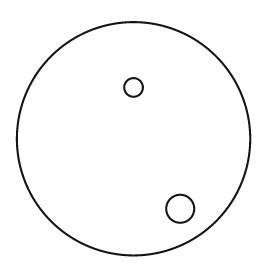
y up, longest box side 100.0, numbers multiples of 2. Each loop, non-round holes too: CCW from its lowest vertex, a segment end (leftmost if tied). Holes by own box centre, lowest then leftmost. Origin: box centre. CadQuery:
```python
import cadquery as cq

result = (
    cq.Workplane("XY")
    .moveTo(0.0, 0.0)
    .circle(50.0)
    .moveTo(20.0, -30.0)
    .circle(6.0)
    .moveTo(0.0, 22.0)
    .circle(4.0)
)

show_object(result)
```